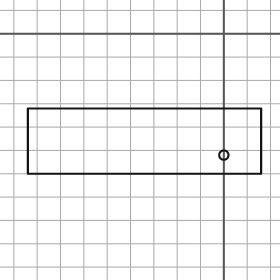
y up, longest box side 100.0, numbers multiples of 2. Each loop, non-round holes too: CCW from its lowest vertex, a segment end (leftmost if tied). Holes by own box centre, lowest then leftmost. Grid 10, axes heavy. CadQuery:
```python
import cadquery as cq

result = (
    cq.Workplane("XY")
    .moveTo(-84.0, -60.0)
    .lineTo(16.0, -60.0)
    .lineTo(16.0, -32.0)
    .lineTo(-84.0, -32.0)
    .close()
    .moveTo(0.0, -52.0)
    .circle(2.0)
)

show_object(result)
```